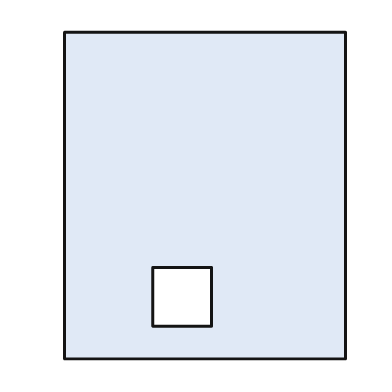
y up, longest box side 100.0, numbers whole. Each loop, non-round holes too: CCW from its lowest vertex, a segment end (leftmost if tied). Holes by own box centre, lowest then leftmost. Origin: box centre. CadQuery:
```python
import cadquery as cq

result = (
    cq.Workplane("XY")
    .moveTo(-43.0, -50.0)
    .lineTo(43.0, -50.0)
    .lineTo(43.0, 50.0)
    .lineTo(-43.0, 50.0)
    .close()
    .moveTo(-16.0, -40.0)
    .lineTo(2.0, -40.0)
    .lineTo(2.0, -22.0)
    .lineTo(-16.0, -22.0)
    .close()
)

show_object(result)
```